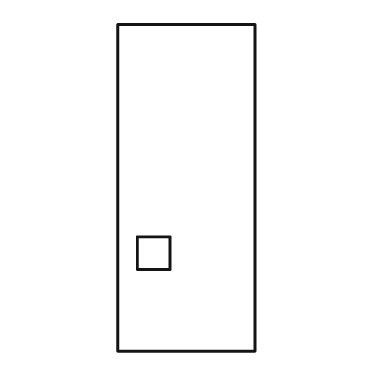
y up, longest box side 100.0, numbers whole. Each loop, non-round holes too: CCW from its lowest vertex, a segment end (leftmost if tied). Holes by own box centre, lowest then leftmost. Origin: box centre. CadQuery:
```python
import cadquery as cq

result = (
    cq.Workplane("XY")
    .moveTo(-21.0, -50.0)
    .lineTo(21.0, -50.0)
    .lineTo(21.0, 50.0)
    .lineTo(-21.0, 50.0)
    .close()
    .moveTo(-15.0, -25.0)
    .lineTo(-5.0, -25.0)
    .lineTo(-5.0, -15.0)
    .lineTo(-15.0, -15.0)
    .close()
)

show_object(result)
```